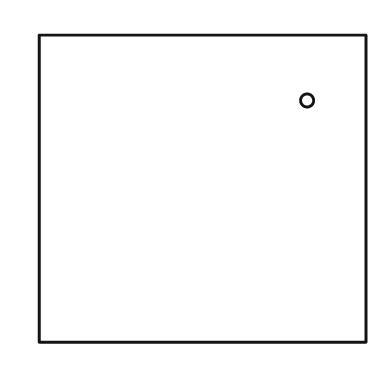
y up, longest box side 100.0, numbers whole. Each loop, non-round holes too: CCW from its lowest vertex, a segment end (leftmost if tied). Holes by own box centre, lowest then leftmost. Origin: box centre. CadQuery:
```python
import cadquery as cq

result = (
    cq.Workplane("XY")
    .moveTo(-50.0, -47.0)
    .lineTo(50.0, -47.0)
    .lineTo(50.0, 47.0)
    .lineTo(-50.0, 47.0)
    .close()
    .moveTo(32.0, 27.0)
    .circle(2.0)
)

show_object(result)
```